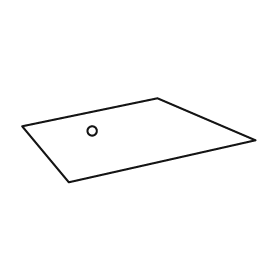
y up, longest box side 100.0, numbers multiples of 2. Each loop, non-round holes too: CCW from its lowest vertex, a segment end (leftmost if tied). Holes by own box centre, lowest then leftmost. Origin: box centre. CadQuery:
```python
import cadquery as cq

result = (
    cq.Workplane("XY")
    .moveTo(-30.0, -18.0)
    .lineTo(50.0, 0.0)
    .lineTo(8.0, 18.0)
    .lineTo(-50.0, 6.0)
    .close()
    .moveTo(-20.0, 4.0)
    .circle(2.0)
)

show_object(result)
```